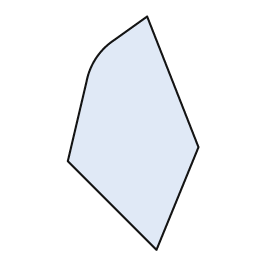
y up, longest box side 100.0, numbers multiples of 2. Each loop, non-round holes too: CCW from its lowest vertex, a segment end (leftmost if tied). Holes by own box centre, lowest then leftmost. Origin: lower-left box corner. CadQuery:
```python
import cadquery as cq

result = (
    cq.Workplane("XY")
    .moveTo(38.0, 0.0)
    .lineTo(56.0, 44.0)
    .lineTo(34.0, 100.0)
    .lineTo(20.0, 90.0)
    .threePointArc((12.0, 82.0), (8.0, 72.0))
    .lineTo(0.0, 38.0)
    .close()
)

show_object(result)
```